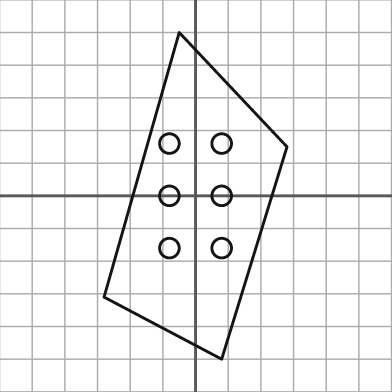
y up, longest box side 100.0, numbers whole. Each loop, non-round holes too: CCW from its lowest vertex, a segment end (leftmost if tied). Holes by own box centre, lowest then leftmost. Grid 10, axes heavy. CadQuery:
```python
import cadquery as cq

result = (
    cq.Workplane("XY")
    .moveTo(8.0, -50.0)
    .lineTo(28.0, 15.0)
    .lineTo(-5.0, 50.0)
    .lineTo(-28.0, -31.0)
    .close()
    .moveTo(-8.0, -16.0)
    .circle(3.0)
    .moveTo(8.0, -16.0)
    .circle(3.0)
    .moveTo(-8.0, 0.0)
    .circle(3.0)
    .moveTo(8.0, 0.0)
    .circle(3.0)
    .moveTo(-8.0, 16.0)
    .circle(3.0)
    .moveTo(8.0, 16.0)
    .circle(3.0)
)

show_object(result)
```